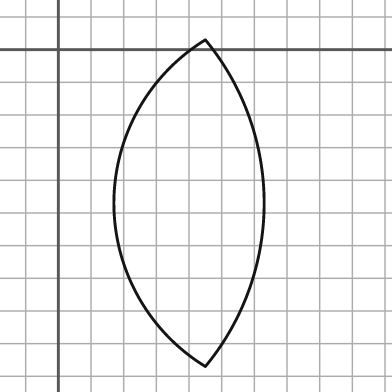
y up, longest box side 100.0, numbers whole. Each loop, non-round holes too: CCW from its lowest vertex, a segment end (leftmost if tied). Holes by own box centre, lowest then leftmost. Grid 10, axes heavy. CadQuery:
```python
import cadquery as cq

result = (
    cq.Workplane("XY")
    .moveTo(45.0, -97.0)
    .threePointArc((63.0, -47.0), (45.0, 3.0))
    .threePointArc((17.0, -47.0), (45.0, -97.0))
    .close()
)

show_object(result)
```